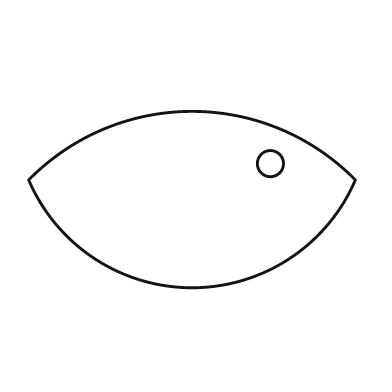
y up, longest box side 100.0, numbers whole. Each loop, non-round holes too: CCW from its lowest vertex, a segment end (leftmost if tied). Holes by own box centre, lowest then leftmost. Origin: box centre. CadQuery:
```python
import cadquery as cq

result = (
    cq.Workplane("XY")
    .moveTo(-50.0, 6.0)
    .threePointArc((0.0, -27.0), (50.0, 6.0))
    .threePointArc((0.0, 27.0), (-50.0, 6.0))
    .close()
    .moveTo(24.0, 11.0)
    .circle(4.0)
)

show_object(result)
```